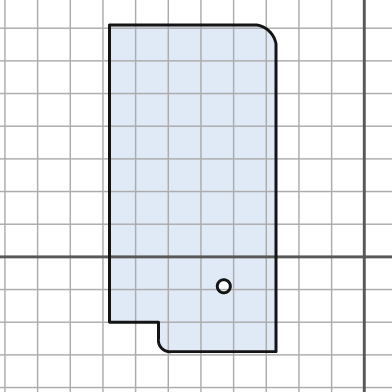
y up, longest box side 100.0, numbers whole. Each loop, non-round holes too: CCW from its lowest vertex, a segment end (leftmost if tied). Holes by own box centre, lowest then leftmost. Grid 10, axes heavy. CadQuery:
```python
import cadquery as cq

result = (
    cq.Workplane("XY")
    .moveTo(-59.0, -29.0)
    .lineTo(-27.0, -29.0)
    .lineTo(-27.0, 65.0)
    .threePointArc((-29.0, 69.0), (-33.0, 71.0))
    .lineTo(-78.0, 71.0)
    .lineTo(-78.0, -20.0)
    .lineTo(-63.0, -20.0)
    .lineTo(-63.0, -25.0)
    .threePointArc((-62.0, -28.0), (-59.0, -29.0))
    .close()
    .moveTo(-43.0, -9.0)
    .circle(2.0)
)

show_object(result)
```